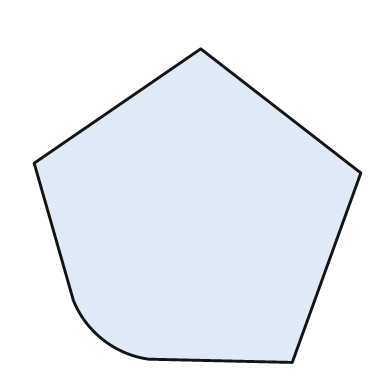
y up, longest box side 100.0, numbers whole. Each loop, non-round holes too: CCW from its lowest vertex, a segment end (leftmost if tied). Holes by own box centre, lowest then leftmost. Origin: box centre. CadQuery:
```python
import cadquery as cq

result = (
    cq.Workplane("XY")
    .moveTo(29.0, -48.0)
    .lineTo(50.0, 10.0)
    .lineTo(1.0, 48.0)
    .lineTo(-50.0, 13.0)
    .lineTo(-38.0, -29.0)
    .threePointArc((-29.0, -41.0), (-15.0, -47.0))
    .close()
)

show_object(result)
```